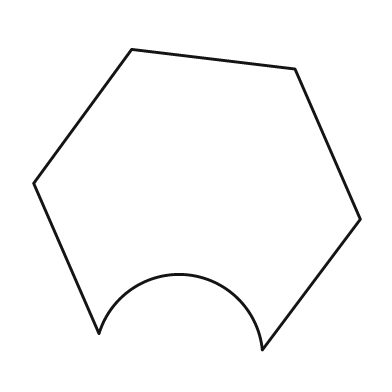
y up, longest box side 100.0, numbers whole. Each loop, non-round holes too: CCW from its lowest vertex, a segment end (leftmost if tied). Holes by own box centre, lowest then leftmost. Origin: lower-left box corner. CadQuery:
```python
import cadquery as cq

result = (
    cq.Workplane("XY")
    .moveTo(70.0, 0.0)
    .lineTo(100.0, 40.0)
    .lineTo(80.0, 86.0)
    .lineTo(30.0, 92.0)
    .lineTo(0.0, 51.0)
    .lineTo(20.0, 5.0)
    .threePointArc((47.0, 23.0), (70.0, 0.0))
    .close()
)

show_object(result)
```